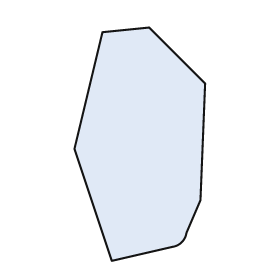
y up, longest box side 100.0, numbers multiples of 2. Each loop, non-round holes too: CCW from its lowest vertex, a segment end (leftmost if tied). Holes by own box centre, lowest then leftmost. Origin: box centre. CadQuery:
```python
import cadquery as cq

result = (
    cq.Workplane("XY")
    .moveTo(-12.0, -50.0)
    .lineTo(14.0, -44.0)
    .threePointArc((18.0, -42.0), (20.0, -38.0))
    .lineTo(26.0, -24.0)
    .lineTo(28.0, 26.0)
    .lineTo(4.0, 50.0)
    .lineTo(-16.0, 48.0)
    .lineTo(-28.0, -2.0)
    .close()
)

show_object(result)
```